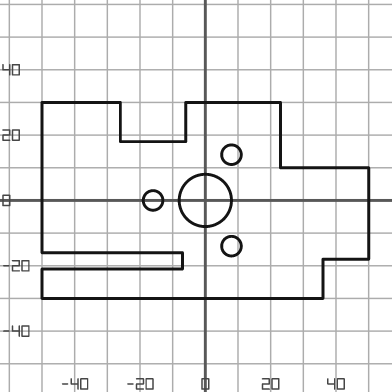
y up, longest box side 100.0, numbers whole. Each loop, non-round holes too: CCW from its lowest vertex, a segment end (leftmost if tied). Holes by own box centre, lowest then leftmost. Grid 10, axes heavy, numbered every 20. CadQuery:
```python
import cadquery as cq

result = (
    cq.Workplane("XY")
    .moveTo(-50.0, -30.0)
    .lineTo(36.0, -30.0)
    .lineTo(36.0, -18.0)
    .lineTo(50.0, -18.0)
    .lineTo(50.0, 10.0)
    .lineTo(23.0, 10.0)
    .lineTo(23.0, 30.0)
    .lineTo(-6.0, 30.0)
    .lineTo(-6.0, 18.0)
    .lineTo(-26.0, 18.0)
    .lineTo(-26.0, 30.0)
    .lineTo(-50.0, 30.0)
    .lineTo(-50.0, -16.0)
    .lineTo(-7.0, -16.0)
    .lineTo(-7.0, -21.0)
    .lineTo(-50.0, -21.0)
    .close()
    .moveTo(8.0, -14.0)
    .circle(3.0)
    .moveTo(-16.0, 0.0)
    .circle(3.0)
    .moveTo(0.0, 0.0)
    .circle(8.0)
    .moveTo(8.0, 14.0)
    .circle(3.0)
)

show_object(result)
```